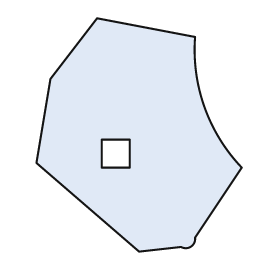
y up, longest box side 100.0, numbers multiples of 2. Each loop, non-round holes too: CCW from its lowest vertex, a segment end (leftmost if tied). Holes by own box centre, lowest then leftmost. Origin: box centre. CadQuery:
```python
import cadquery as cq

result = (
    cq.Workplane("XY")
    .moveTo(0.0, -50.0)
    .lineTo(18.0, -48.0)
    .threePointArc((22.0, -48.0), (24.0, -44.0))
    .lineTo(44.0, -14.0)
    .threePointArc((28.0, 12.0), (24.0, 42.0))
    .lineTo(-18.0, 50.0)
    .lineTo(-38.0, 24.0)
    .lineTo(-44.0, -12.0)
    .close()
    .moveTo(-16.0, -14.0)
    .lineTo(-4.0, -14.0)
    .lineTo(-4.0, -2.0)
    .lineTo(-16.0, -2.0)
    .close()
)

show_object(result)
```